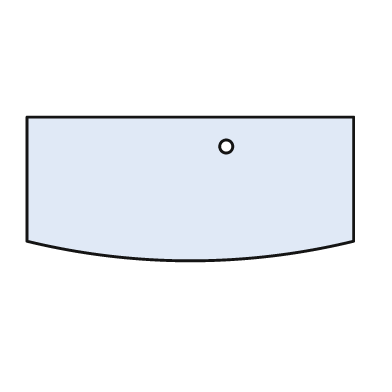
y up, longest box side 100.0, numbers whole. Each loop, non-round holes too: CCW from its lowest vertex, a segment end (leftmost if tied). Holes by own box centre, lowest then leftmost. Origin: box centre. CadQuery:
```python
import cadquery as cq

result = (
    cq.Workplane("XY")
    .moveTo(-50.0, -16.0)
    .threePointArc((0.0, -22.0), (50.0, -16.0))
    .lineTo(50.0, 22.0)
    .lineTo(-50.0, 22.0)
    .close()
    .moveTo(11.0, 13.0)
    .circle(2.0)
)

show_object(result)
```